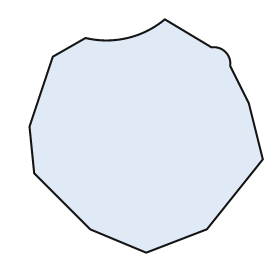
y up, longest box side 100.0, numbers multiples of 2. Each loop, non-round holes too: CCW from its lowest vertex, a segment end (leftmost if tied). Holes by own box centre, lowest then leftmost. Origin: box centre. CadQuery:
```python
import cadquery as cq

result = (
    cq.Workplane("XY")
    .moveTo(0.0, -50.0)
    .lineTo(26.0, -40.0)
    .lineTo(50.0, -10.0)
    .lineTo(44.0, 14.0)
    .lineTo(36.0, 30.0)
    .threePointArc((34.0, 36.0), (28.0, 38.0))
    .lineTo(8.0, 50.0)
    .threePointArc((-8.0, 42.0), (-26.0, 42.0))
    .lineTo(-40.0, 34.0)
    .lineTo(-50.0, 4.0)
    .lineTo(-48.0, -16.0)
    .lineTo(-24.0, -40.0)
    .close()
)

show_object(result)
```